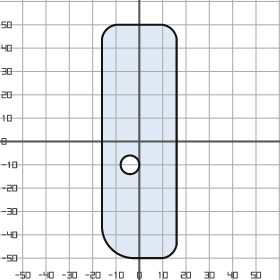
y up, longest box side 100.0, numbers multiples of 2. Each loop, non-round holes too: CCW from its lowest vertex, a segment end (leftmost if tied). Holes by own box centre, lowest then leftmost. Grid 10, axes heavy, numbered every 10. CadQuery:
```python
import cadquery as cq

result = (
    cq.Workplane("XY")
    .moveTo(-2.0, -50.0)
    .lineTo(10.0, -50.0)
    .threePointArc((14.0, -48.0), (16.0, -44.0))
    .lineTo(16.0, 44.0)
    .threePointArc((14.0, 48.0), (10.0, 50.0))
    .lineTo(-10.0, 50.0)
    .threePointArc((-14.0, 48.0), (-16.0, 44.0))
    .lineTo(-16.0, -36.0)
    .threePointArc((-12.0, -46.0), (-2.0, -50.0))
    .close()
    .moveTo(-4.0, -10.0)
    .circle(4.0)
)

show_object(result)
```